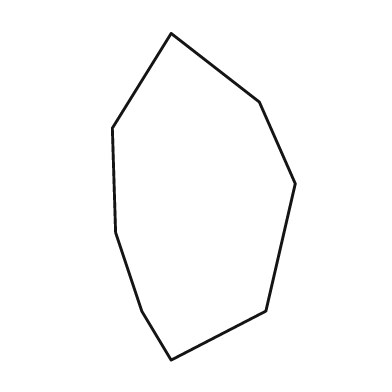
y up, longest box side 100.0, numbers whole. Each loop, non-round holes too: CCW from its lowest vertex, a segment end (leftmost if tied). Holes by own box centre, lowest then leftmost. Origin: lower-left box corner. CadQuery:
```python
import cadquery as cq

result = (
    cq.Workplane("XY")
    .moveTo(18.0, 0.0)
    .lineTo(47.0, 15.0)
    .lineTo(56.0, 54.0)
    .lineTo(45.0, 79.0)
    .lineTo(18.0, 100.0)
    .lineTo(0.0, 71.0)
    .lineTo(1.0, 39.0)
    .lineTo(9.0, 15.0)
    .close()
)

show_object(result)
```